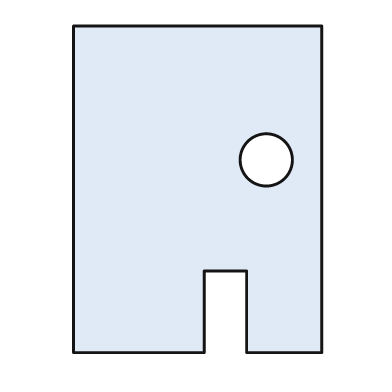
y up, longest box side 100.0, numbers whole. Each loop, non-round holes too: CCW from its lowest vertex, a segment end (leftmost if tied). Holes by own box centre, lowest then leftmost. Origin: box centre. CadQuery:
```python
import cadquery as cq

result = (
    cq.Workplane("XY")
    .moveTo(-38.0, -50.0)
    .lineTo(2.0, -50.0)
    .lineTo(2.0, -25.0)
    .lineTo(15.0, -25.0)
    .lineTo(15.0, -50.0)
    .lineTo(38.0, -50.0)
    .lineTo(38.0, 50.0)
    .lineTo(-38.0, 50.0)
    .close()
    .moveTo(21.0, 9.0)
    .circle(8.0)
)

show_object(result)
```